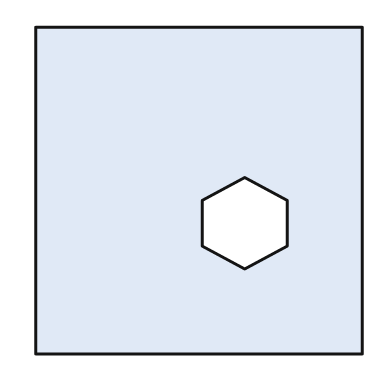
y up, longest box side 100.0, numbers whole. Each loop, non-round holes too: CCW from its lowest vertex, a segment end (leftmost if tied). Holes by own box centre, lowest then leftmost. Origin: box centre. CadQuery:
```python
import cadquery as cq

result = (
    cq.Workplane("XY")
    .moveTo(-50.0, -50.0)
    .lineTo(50.0, -50.0)
    .lineTo(50.0, 50.0)
    .lineTo(-50.0, 50.0)
    .close()
    .moveTo(14.0, -24.0)
    .lineTo(27.0, -17.0)
    .lineTo(27.0, -3.0)
    .lineTo(14.0, 4.0)
    .lineTo(1.0, -3.0)
    .lineTo(1.0, -17.0)
    .close()
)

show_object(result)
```